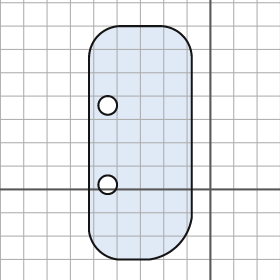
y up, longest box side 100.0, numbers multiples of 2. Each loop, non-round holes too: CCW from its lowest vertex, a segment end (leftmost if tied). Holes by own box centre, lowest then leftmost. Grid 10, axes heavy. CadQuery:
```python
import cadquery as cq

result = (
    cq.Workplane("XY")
    .moveTo(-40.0, -30.0)
    .lineTo(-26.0, -30.0)
    .threePointArc((-14.0, -24.0), (-8.0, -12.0))
    .lineTo(-8.0, 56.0)
    .threePointArc((-12.0, 66.0), (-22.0, 70.0))
    .lineTo(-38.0, 70.0)
    .threePointArc((-48.0, 66.0), (-52.0, 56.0))
    .lineTo(-52.0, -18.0)
    .threePointArc((-48.0, -26.0), (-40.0, -30.0))
    .close()
    .moveTo(-44.0, 2.0)
    .circle(4.0)
    .moveTo(-44.0, 36.0)
    .circle(4.0)
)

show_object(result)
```